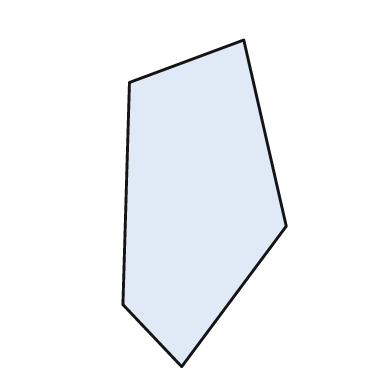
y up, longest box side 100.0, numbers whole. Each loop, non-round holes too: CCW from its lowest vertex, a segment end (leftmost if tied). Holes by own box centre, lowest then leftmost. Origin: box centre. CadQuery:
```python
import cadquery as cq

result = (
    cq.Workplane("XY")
    .moveTo(-7.0, -50.0)
    .lineTo(25.0, -7.0)
    .lineTo(12.0, 50.0)
    .lineTo(-23.0, 37.0)
    .lineTo(-25.0, -31.0)
    .close()
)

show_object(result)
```